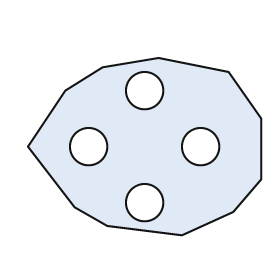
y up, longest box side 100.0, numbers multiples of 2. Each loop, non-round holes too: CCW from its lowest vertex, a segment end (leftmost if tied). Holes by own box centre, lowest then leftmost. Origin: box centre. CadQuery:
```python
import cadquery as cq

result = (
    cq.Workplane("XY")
    .moveTo(16.0, -38.0)
    .lineTo(38.0, -28.0)
    .lineTo(50.0, -14.0)
    .lineTo(50.0, 12.0)
    .lineTo(36.0, 32.0)
    .lineTo(6.0, 38.0)
    .lineTo(-18.0, 34.0)
    .lineTo(-34.0, 24.0)
    .lineTo(-50.0, 0.0)
    .lineTo(-30.0, -26.0)
    .lineTo(-16.0, -34.0)
    .close()
    .moveTo(0.0, -24.0)
    .circle(8.0)
    .moveTo(-24.0, 0.0)
    .circle(8.0)
    .moveTo(24.0, 0.0)
    .circle(8.0)
    .moveTo(0.0, 24.0)
    .circle(8.0)
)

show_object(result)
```